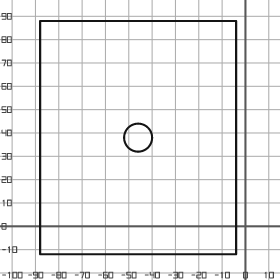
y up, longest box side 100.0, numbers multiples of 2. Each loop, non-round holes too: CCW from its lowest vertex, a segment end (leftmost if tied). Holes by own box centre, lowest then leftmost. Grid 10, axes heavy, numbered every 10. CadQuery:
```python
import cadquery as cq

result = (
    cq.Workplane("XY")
    .moveTo(-88.0, -12.0)
    .lineTo(-4.0, -12.0)
    .lineTo(-4.0, 88.0)
    .lineTo(-88.0, 88.0)
    .close()
    .moveTo(-46.0, 38.0)
    .circle(6.0)
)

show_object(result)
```